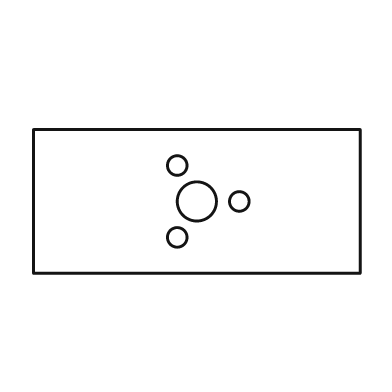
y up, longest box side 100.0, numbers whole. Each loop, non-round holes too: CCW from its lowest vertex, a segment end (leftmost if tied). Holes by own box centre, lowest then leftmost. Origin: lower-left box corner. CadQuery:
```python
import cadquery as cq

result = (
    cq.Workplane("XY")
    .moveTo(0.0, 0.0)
    .lineTo(100.0, 0.0)
    .lineTo(100.0, 44.0)
    .lineTo(0.0, 44.0)
    .close()
    .moveTo(44.0, 11.0)
    .circle(3.0)
    .moveTo(50.0, 22.0)
    .circle(6.0)
    .moveTo(63.0, 22.0)
    .circle(3.0)
    .moveTo(44.0, 33.0)
    .circle(3.0)
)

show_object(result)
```